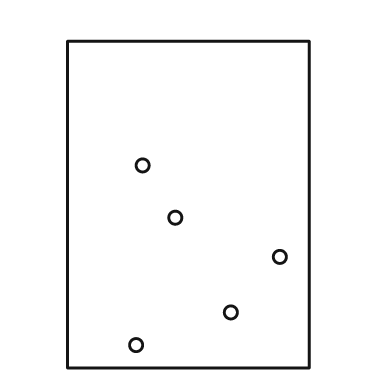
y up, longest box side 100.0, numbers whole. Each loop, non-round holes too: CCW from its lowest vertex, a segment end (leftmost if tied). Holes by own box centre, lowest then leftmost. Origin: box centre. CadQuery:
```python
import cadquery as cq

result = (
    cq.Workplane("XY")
    .moveTo(-37.0, -50.0)
    .lineTo(37.0, -50.0)
    .lineTo(37.0, 50.0)
    .lineTo(-37.0, 50.0)
    .close()
    .moveTo(-16.0, -43.0)
    .circle(2.0)
    .moveTo(13.0, -33.0)
    .circle(2.0)
    .moveTo(28.0, -16.0)
    .circle(2.0)
    .moveTo(-4.0, -4.0)
    .circle(2.0)
    .moveTo(-14.0, 12.0)
    .circle(2.0)
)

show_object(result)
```